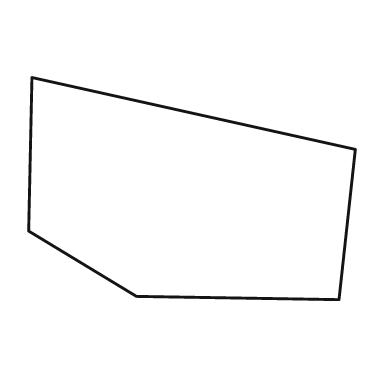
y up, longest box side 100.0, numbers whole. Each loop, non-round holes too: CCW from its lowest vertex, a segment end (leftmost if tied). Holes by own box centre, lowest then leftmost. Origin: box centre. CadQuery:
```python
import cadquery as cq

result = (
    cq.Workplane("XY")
    .moveTo(45.0, -34.0)
    .lineTo(50.0, 12.0)
    .lineTo(-49.0, 34.0)
    .lineTo(-50.0, -13.0)
    .lineTo(-17.0, -33.0)
    .close()
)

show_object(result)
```